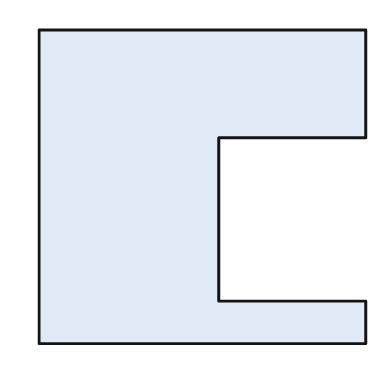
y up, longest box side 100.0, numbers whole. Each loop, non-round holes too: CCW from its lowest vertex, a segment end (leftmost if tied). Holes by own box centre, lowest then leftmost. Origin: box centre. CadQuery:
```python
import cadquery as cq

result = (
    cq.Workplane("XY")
    .moveTo(-50.0, -48.0)
    .lineTo(50.0, -48.0)
    .lineTo(50.0, -35.0)
    .lineTo(5.0, -35.0)
    .lineTo(5.0, 15.0)
    .lineTo(50.0, 15.0)
    .lineTo(50.0, 48.0)
    .lineTo(-50.0, 48.0)
    .close()
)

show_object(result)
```